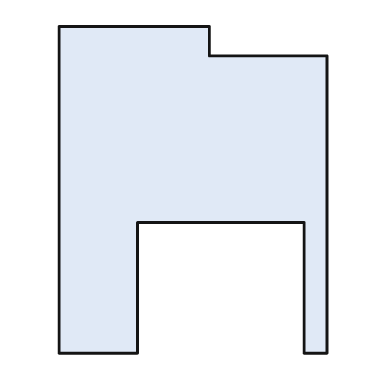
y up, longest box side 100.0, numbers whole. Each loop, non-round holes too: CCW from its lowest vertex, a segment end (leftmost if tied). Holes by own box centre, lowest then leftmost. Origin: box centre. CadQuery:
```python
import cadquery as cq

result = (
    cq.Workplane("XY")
    .moveTo(-41.0, -50.0)
    .lineTo(-17.0, -50.0)
    .lineTo(-17.0, -10.0)
    .lineTo(34.0, -10.0)
    .lineTo(34.0, -50.0)
    .lineTo(41.0, -50.0)
    .lineTo(41.0, 41.0)
    .lineTo(5.0, 41.0)
    .lineTo(5.0, 50.0)
    .lineTo(-41.0, 50.0)
    .close()
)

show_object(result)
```